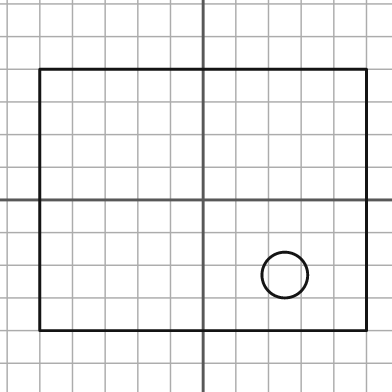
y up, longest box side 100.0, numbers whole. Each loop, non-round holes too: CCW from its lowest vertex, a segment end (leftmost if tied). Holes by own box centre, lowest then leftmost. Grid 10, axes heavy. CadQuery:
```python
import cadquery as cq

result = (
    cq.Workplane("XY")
    .moveTo(-50.0, -40.0)
    .lineTo(50.0, -40.0)
    .lineTo(50.0, 40.0)
    .lineTo(-50.0, 40.0)
    .close()
    .moveTo(25.0, -23.0)
    .circle(7.0)
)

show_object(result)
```